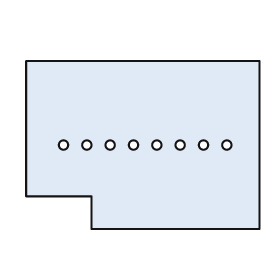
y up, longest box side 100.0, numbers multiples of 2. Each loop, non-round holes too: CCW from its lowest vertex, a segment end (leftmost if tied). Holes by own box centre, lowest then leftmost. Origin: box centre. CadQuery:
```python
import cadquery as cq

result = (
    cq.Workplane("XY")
    .moveTo(-22.0, -36.0)
    .lineTo(50.0, -36.0)
    .lineTo(50.0, 36.0)
    .lineTo(-50.0, 36.0)
    .lineTo(-50.0, -22.0)
    .lineTo(-22.0, -22.0)
    .close()
    .moveTo(-34.0, 0.0)
    .circle(2.0)
    .moveTo(-24.0, 0.0)
    .circle(2.0)
    .moveTo(-14.0, 0.0)
    .circle(2.0)
    .moveTo(-4.0, 0.0)
    .circle(2.0)
    .moveTo(6.0, 0.0)
    .circle(2.0)
    .moveTo(16.0, 0.0)
    .circle(2.0)
    .moveTo(26.0, 0.0)
    .circle(2.0)
    .moveTo(36.0, 0.0)
    .circle(2.0)
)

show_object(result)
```